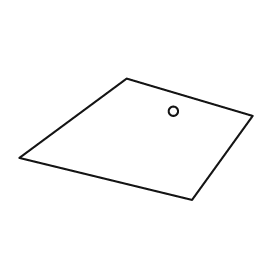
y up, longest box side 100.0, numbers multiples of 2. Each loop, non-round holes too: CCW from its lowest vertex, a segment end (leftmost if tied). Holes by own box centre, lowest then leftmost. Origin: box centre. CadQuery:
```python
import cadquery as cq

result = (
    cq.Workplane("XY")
    .moveTo(24.0, -26.0)
    .lineTo(50.0, 10.0)
    .lineTo(-4.0, 26.0)
    .lineTo(-50.0, -8.0)
    .close()
    .moveTo(16.0, 12.0)
    .circle(2.0)
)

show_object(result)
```